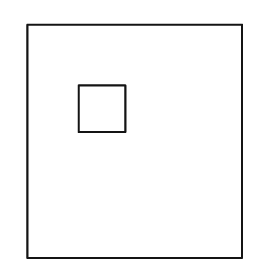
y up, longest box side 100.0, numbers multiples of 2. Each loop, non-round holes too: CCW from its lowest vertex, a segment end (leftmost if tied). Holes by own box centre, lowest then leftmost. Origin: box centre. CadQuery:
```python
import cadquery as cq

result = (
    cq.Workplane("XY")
    .moveTo(-46.0, -50.0)
    .lineTo(46.0, -50.0)
    .lineTo(46.0, 50.0)
    .lineTo(-46.0, 50.0)
    .close()
    .moveTo(-24.0, 4.0)
    .lineTo(-4.0, 4.0)
    .lineTo(-4.0, 24.0)
    .lineTo(-24.0, 24.0)
    .close()
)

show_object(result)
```